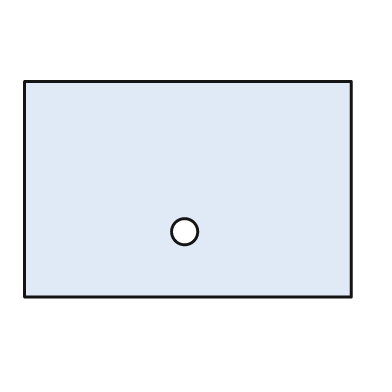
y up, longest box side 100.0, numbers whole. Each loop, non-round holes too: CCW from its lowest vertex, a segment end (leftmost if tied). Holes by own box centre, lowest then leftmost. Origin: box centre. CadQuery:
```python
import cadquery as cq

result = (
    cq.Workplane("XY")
    .moveTo(-50.0, -33.0)
    .lineTo(50.0, -33.0)
    .lineTo(50.0, 33.0)
    .lineTo(-50.0, 33.0)
    .close()
    .moveTo(-1.0, -13.0)
    .circle(4.0)
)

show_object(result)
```